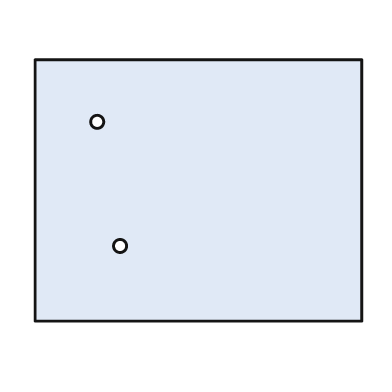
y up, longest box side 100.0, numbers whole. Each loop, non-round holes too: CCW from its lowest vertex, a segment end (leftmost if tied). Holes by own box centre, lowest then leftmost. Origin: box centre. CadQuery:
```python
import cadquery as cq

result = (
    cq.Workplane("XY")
    .moveTo(-50.0, -40.0)
    .lineTo(50.0, -40.0)
    .lineTo(50.0, 40.0)
    .lineTo(-50.0, 40.0)
    .close()
    .moveTo(-24.0, -17.0)
    .circle(2.0)
    .moveTo(-31.0, 21.0)
    .circle(2.0)
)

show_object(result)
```